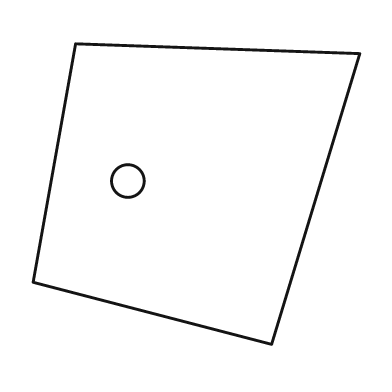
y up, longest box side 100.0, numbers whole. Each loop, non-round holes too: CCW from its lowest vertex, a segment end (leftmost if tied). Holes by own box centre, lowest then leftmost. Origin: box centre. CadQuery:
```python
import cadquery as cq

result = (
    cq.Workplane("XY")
    .moveTo(23.0, -46.0)
    .lineTo(50.0, 43.0)
    .lineTo(-37.0, 46.0)
    .lineTo(-50.0, -27.0)
    .close()
    .moveTo(-21.0, 4.0)
    .circle(5.0)
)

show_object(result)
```